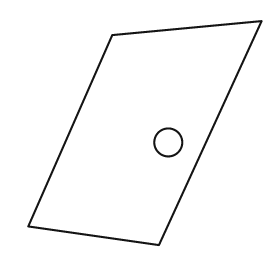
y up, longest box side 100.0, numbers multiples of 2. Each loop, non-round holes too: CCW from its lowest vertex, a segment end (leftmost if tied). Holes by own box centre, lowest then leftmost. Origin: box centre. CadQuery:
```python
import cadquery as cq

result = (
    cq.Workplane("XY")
    .moveTo(6.0, -48.0)
    .lineTo(50.0, 48.0)
    .lineTo(-14.0, 42.0)
    .lineTo(-50.0, -40.0)
    .close()
    .moveTo(10.0, -4.0)
    .circle(6.0)
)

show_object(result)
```